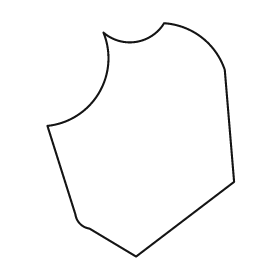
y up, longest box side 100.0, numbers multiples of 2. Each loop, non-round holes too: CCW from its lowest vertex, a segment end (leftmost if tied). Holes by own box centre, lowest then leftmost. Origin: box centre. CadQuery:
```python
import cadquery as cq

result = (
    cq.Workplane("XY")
    .moveTo(-2.0, -50.0)
    .lineTo(40.0, -18.0)
    .lineTo(36.0, 30.0)
    .threePointArc((26.0, 44.0), (10.0, 50.0))
    .threePointArc((-2.0, 42.0), (-16.0, 46.0))
    .threePointArc((-18.0, 20.0), (-40.0, 6.0))
    .lineTo(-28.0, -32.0)
    .threePointArc((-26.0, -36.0), (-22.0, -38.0))
    .close()
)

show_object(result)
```